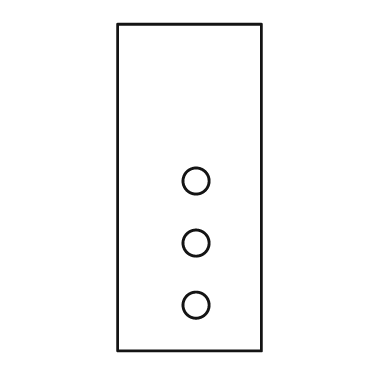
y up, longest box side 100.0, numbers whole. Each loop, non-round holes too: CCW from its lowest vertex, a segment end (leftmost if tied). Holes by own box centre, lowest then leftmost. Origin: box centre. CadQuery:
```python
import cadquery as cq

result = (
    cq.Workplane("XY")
    .moveTo(-22.0, -50.0)
    .lineTo(22.0, -50.0)
    .lineTo(22.0, 50.0)
    .lineTo(-22.0, 50.0)
    .close()
    .moveTo(2.0, -36.0)
    .circle(4.0)
    .moveTo(2.0, -17.0)
    .circle(4.0)
    .moveTo(2.0, 2.0)
    .circle(4.0)
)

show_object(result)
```